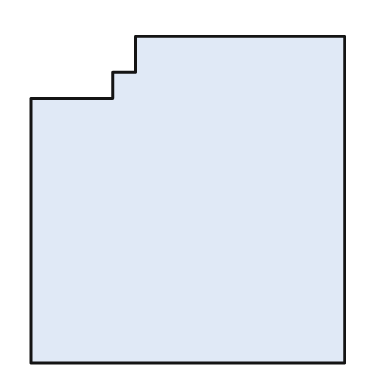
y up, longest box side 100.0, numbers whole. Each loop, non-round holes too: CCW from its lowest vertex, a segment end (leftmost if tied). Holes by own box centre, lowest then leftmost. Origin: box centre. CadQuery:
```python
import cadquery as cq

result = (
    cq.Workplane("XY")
    .moveTo(-48.0, -50.0)
    .lineTo(48.0, -50.0)
    .lineTo(48.0, 50.0)
    .lineTo(-16.0, 50.0)
    .lineTo(-16.0, 39.0)
    .lineTo(-23.0, 39.0)
    .lineTo(-23.0, 31.0)
    .lineTo(-48.0, 31.0)
    .close()
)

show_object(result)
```